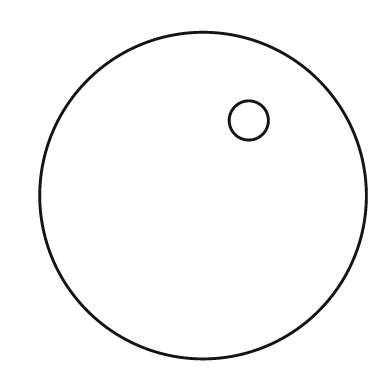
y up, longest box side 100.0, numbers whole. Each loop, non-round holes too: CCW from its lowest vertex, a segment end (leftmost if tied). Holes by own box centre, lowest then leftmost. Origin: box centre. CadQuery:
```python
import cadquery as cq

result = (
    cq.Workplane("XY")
    .moveTo(0.0, 0.0)
    .circle(50.0)
    .moveTo(14.0, 23.0)
    .circle(6.0)
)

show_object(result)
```